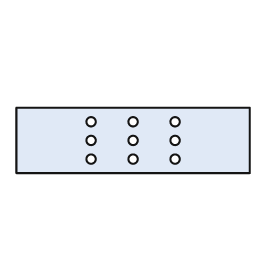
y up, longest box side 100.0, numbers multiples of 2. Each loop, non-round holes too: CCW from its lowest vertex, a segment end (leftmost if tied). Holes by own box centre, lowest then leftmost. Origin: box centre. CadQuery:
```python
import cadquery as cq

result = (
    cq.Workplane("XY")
    .moveTo(-50.0, -14.0)
    .lineTo(50.0, -14.0)
    .lineTo(50.0, 14.0)
    .lineTo(-50.0, 14.0)
    .close()
    .moveTo(-18.0, -8.0)
    .circle(2.0)
    .moveTo(0.0, -8.0)
    .circle(2.0)
    .moveTo(18.0, -8.0)
    .circle(2.0)
    .moveTo(-18.0, 0.0)
    .circle(2.0)
    .moveTo(0.0, 0.0)
    .circle(2.0)
    .moveTo(18.0, 0.0)
    .circle(2.0)
    .moveTo(-18.0, 8.0)
    .circle(2.0)
    .moveTo(0.0, 8.0)
    .circle(2.0)
    .moveTo(18.0, 8.0)
    .circle(2.0)
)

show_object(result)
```